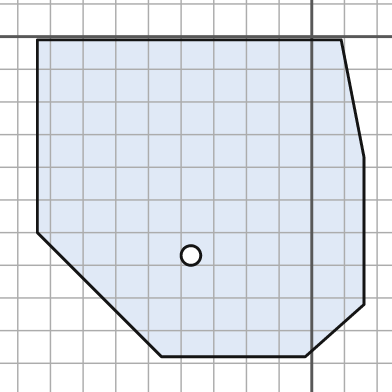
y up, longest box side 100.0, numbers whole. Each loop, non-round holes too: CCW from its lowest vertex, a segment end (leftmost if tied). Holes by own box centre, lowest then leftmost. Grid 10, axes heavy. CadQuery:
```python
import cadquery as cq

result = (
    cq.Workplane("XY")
    .moveTo(-46.0, -98.0)
    .lineTo(-2.0, -98.0)
    .lineTo(16.0, -82.0)
    .lineTo(16.0, -37.0)
    .lineTo(9.0, -1.0)
    .lineTo(-84.0, -1.0)
    .lineTo(-84.0, -60.0)
    .close()
    .moveTo(-37.0, -67.0)
    .circle(3.0)
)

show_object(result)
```